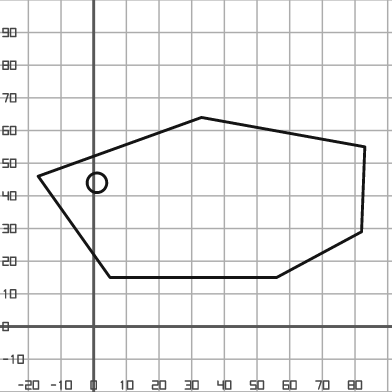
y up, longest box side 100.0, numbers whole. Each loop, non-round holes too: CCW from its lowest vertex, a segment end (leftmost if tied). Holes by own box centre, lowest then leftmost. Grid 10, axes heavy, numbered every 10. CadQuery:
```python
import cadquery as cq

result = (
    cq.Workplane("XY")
    .moveTo(5.0, 15.0)
    .lineTo(56.0, 15.0)
    .lineTo(82.0, 29.0)
    .lineTo(83.0, 55.0)
    .lineTo(33.0, 64.0)
    .lineTo(-17.0, 46.0)
    .close()
    .moveTo(1.0, 44.0)
    .circle(3.0)
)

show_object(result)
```